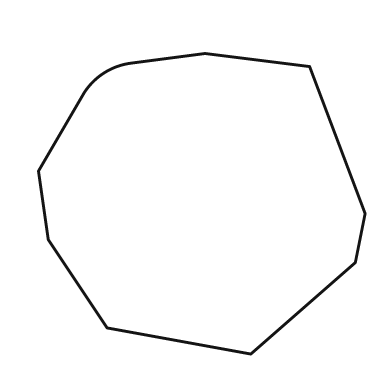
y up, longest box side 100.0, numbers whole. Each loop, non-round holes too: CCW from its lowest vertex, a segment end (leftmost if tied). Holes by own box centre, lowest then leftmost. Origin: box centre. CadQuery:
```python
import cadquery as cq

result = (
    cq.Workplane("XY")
    .moveTo(15.0, -46.0)
    .lineTo(47.0, -18.0)
    .lineTo(50.0, -3.0)
    .lineTo(33.0, 42.0)
    .lineTo(1.0, 46.0)
    .lineTo(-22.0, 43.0)
    .threePointArc((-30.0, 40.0), (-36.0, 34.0))
    .lineTo(-50.0, 10.0)
    .lineTo(-47.0, -11.0)
    .lineTo(-29.0, -38.0)
    .close()
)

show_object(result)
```